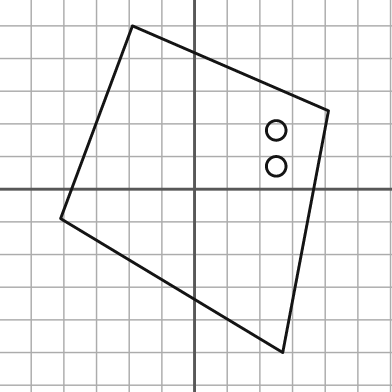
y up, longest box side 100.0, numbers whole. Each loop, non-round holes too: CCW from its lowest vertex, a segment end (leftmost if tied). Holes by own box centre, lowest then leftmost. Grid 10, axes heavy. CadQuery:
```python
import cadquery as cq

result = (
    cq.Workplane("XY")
    .moveTo(27.0, -50.0)
    .lineTo(41.0, 24.0)
    .lineTo(-19.0, 50.0)
    .lineTo(-41.0, -9.0)
    .close()
    .moveTo(25.0, 7.0)
    .circle(3.0)
    .moveTo(25.0, 18.0)
    .circle(3.0)
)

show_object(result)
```